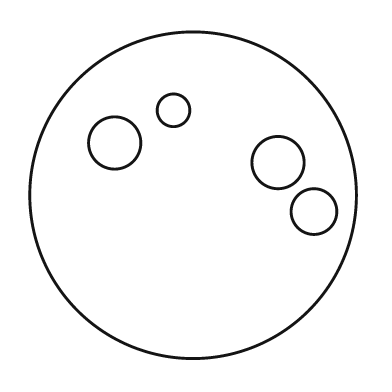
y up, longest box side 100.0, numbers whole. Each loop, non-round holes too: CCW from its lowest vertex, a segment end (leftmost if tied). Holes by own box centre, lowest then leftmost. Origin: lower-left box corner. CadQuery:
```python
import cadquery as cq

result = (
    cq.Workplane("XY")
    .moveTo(50.0, 50.0)
    .circle(50.0)
    .moveTo(87.0, 45.0)
    .circle(7.0)
    .moveTo(76.0, 60.0)
    .circle(8.0)
    .moveTo(26.0, 66.0)
    .circle(8.0)
    .moveTo(44.0, 76.0)
    .circle(5.0)
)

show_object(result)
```